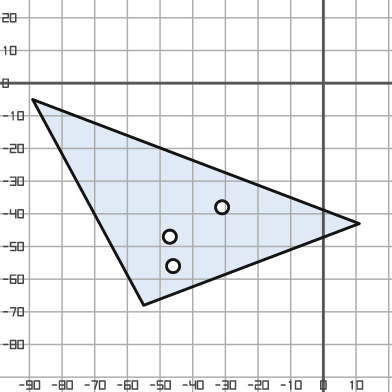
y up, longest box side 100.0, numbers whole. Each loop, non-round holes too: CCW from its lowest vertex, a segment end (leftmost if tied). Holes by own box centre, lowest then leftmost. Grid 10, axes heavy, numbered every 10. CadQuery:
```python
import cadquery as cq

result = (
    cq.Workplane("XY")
    .moveTo(-55.0, -68.0)
    .lineTo(11.0, -43.0)
    .lineTo(-89.0, -5.0)
    .close()
    .moveTo(-46.0, -56.0)
    .circle(2.0)
    .moveTo(-47.0, -47.0)
    .circle(2.0)
    .moveTo(-31.0, -38.0)
    .circle(2.0)
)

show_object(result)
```